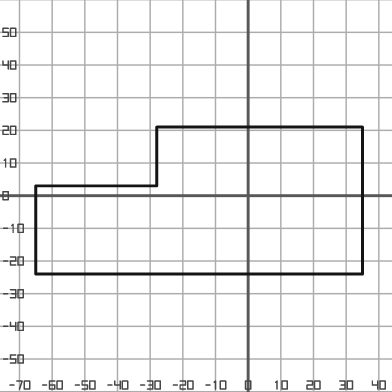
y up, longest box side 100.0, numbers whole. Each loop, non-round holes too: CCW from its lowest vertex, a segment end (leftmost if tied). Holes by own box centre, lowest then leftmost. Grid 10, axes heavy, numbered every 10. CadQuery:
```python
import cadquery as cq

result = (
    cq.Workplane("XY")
    .moveTo(-65.0, -24.0)
    .lineTo(35.0, -24.0)
    .lineTo(35.0, 21.0)
    .lineTo(-28.0, 21.0)
    .lineTo(-28.0, 3.0)
    .lineTo(-65.0, 3.0)
    .close()
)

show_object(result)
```